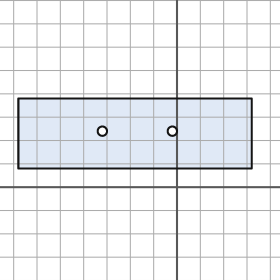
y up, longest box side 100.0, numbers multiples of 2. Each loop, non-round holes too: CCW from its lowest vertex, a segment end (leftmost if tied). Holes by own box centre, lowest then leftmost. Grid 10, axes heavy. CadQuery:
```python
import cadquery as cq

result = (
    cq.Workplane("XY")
    .moveTo(-68.0, 8.0)
    .lineTo(32.0, 8.0)
    .lineTo(32.0, 38.0)
    .lineTo(-68.0, 38.0)
    .close()
    .moveTo(-32.0, 24.0)
    .circle(2.0)
    .moveTo(-2.0, 24.0)
    .circle(2.0)
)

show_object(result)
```